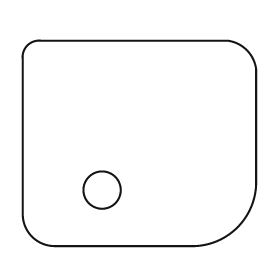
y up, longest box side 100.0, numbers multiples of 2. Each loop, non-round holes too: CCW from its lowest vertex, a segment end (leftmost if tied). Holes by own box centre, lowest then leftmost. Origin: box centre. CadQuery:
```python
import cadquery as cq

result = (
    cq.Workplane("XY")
    .moveTo(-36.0, -44.0)
    .lineTo(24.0, -44.0)
    .threePointArc((42.0, -36.0), (50.0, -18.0))
    .lineTo(50.0, 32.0)
    .threePointArc((46.0, 40.0), (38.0, 44.0))
    .lineTo(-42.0, 44.0)
    .threePointArc((-48.0, 42.0), (-50.0, 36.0))
    .lineTo(-50.0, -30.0)
    .threePointArc((-46.0, -40.0), (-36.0, -44.0))
    .close()
    .moveTo(-16.0, -20.0)
    .circle(8.0)
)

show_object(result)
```